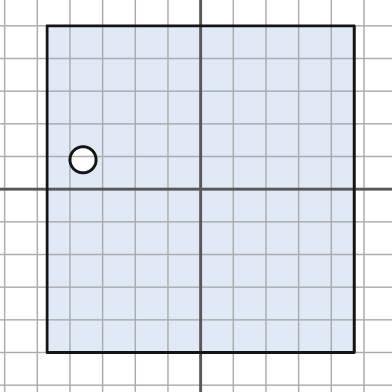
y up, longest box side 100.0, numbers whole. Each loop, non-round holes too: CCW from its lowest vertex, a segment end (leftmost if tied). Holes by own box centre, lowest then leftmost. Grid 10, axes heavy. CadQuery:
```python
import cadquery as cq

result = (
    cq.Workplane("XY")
    .moveTo(-47.0, -50.0)
    .lineTo(47.0, -50.0)
    .lineTo(47.0, 50.0)
    .lineTo(-47.0, 50.0)
    .close()
    .moveTo(-36.0, 9.0)
    .circle(4.0)
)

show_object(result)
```